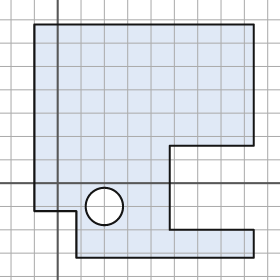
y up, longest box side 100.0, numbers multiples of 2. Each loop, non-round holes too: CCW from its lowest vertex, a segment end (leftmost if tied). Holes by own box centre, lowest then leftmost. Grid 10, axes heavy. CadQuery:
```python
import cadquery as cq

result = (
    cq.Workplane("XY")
    .moveTo(8.0, -32.0)
    .lineTo(84.0, -32.0)
    .lineTo(84.0, -20.0)
    .lineTo(48.0, -20.0)
    .lineTo(48.0, 16.0)
    .lineTo(84.0, 16.0)
    .lineTo(84.0, 68.0)
    .lineTo(-10.0, 68.0)
    .lineTo(-10.0, -12.0)
    .lineTo(8.0, -12.0)
    .close()
    .moveTo(20.0, -10.0)
    .circle(8.0)
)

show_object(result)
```